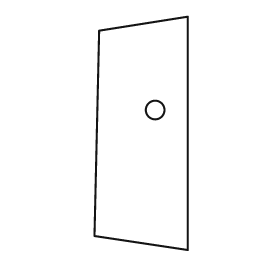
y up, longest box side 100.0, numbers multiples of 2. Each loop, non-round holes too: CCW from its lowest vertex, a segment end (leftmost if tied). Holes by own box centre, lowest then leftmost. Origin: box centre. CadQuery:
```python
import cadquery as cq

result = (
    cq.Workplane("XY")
    .moveTo(20.0, -50.0)
    .lineTo(20.0, 50.0)
    .lineTo(-18.0, 44.0)
    .lineTo(-20.0, -44.0)
    .close()
    .moveTo(6.0, 10.0)
    .circle(4.0)
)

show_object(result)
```